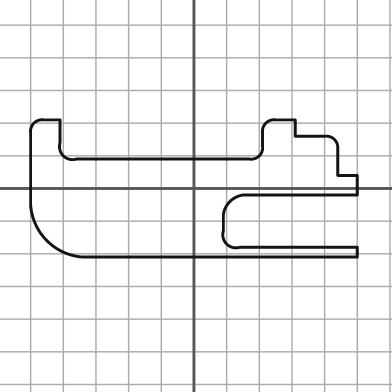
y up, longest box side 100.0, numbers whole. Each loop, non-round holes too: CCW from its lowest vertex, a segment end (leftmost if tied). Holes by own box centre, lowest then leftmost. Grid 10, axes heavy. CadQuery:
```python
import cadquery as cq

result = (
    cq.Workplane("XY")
    .moveTo(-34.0, -21.0)
    .lineTo(50.0, -21.0)
    .lineTo(50.0, -18.0)
    .lineTo(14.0, -18.0)
    .threePointArc((10.0, -17.0), (9.0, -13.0))
    .lineTo(9.0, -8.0)
    .threePointArc((11.0, -4.0), (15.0, -2.0))
    .lineTo(50.0, -2.0)
    .lineTo(50.0, 4.0)
    .lineTo(44.0, 4.0)
    .lineTo(44.0, 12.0)
    .threePointArc((43.0, 15.0), (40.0, 16.0))
    .lineTo(31.0, 16.0)
    .lineTo(31.0, 21.0)
    .lineTo(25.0, 21.0)
    .threePointArc((22.0, 20.0), (21.0, 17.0))
    .lineTo(21.0, 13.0)
    .threePointArc((20.0, 10.0), (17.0, 9.0))
    .lineTo(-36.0, 9.0)
    .threePointArc((-40.0, 10.0), (-41.0, 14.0))
    .lineTo(-41.0, 21.0)
    .lineTo(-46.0, 21.0)
    .threePointArc((-49.0, 20.0), (-50.0, 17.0))
    .lineTo(-50.0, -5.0)
    .threePointArc((-45.0, -16.0), (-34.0, -21.0))
    .close()
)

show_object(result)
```